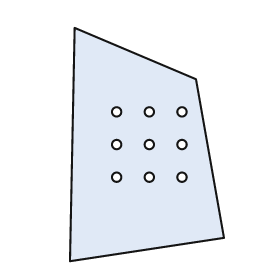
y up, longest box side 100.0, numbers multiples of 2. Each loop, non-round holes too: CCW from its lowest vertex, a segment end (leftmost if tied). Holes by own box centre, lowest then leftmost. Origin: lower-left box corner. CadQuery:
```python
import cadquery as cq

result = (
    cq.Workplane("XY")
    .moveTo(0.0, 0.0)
    .lineTo(66.0, 10.0)
    .lineTo(54.0, 78.0)
    .lineTo(2.0, 100.0)
    .close()
    .moveTo(20.0, 36.0)
    .circle(2.0)
    .moveTo(34.0, 36.0)
    .circle(2.0)
    .moveTo(48.0, 36.0)
    .circle(2.0)
    .moveTo(20.0, 50.0)
    .circle(2.0)
    .moveTo(34.0, 50.0)
    .circle(2.0)
    .moveTo(48.0, 50.0)
    .circle(2.0)
    .moveTo(20.0, 64.0)
    .circle(2.0)
    .moveTo(34.0, 64.0)
    .circle(2.0)
    .moveTo(48.0, 64.0)
    .circle(2.0)
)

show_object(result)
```